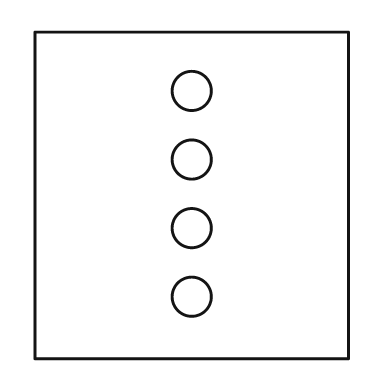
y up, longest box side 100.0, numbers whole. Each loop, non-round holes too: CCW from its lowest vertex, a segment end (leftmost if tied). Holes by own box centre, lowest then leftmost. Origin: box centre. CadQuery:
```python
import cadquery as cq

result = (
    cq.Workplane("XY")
    .moveTo(-48.0, -50.0)
    .lineTo(48.0, -50.0)
    .lineTo(48.0, 50.0)
    .lineTo(-48.0, 50.0)
    .close()
    .moveTo(0.0, -31.0)
    .circle(6.0)
    .moveTo(0.0, -10.0)
    .circle(6.0)
    .moveTo(0.0, 11.0)
    .circle(6.0)
    .moveTo(0.0, 32.0)
    .circle(6.0)
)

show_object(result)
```